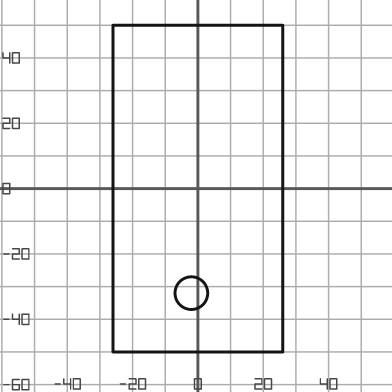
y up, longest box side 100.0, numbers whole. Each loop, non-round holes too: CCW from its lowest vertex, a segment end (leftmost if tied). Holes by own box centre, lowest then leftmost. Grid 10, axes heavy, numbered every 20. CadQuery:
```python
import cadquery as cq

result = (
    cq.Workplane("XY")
    .moveTo(-26.0, -50.0)
    .lineTo(26.0, -50.0)
    .lineTo(26.0, 50.0)
    .lineTo(-26.0, 50.0)
    .close()
    .moveTo(-2.0, -32.0)
    .circle(5.0)
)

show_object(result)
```